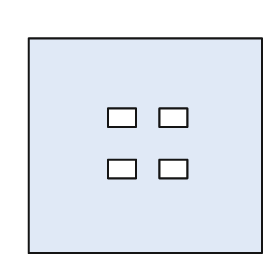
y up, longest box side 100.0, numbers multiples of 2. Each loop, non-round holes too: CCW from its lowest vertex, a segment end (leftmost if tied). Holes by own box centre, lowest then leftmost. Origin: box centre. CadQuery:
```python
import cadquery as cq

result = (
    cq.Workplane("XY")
    .moveTo(-50.0, -46.0)
    .lineTo(50.0, -46.0)
    .lineTo(50.0, 46.0)
    .lineTo(-50.0, 46.0)
    .close()
    .moveTo(-16.0, -14.0)
    .lineTo(-4.0, -14.0)
    .lineTo(-4.0, -6.0)
    .lineTo(-16.0, -6.0)
    .close()
    .moveTo(6.0, -14.0)
    .lineTo(18.0, -14.0)
    .lineTo(18.0, -6.0)
    .lineTo(6.0, -6.0)
    .close()
    .moveTo(-16.0, 8.0)
    .lineTo(-4.0, 8.0)
    .lineTo(-4.0, 16.0)
    .lineTo(-16.0, 16.0)
    .close()
    .moveTo(6.0, 8.0)
    .lineTo(18.0, 8.0)
    .lineTo(18.0, 16.0)
    .lineTo(6.0, 16.0)
    .close()
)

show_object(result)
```